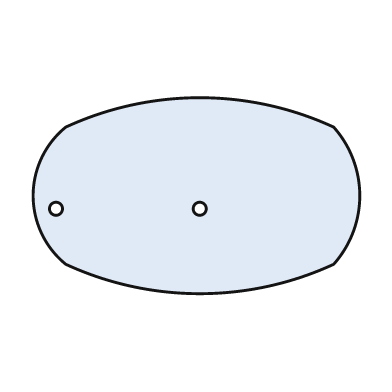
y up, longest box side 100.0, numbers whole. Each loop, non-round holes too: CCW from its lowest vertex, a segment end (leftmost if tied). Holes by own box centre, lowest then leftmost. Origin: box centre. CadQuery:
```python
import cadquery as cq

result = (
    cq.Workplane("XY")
    .moveTo(-40.0, -21.0)
    .threePointArc((1.0, -30.0), (42.0, -21.0))
    .threePointArc((50.0, 0.0), (42.0, 21.0))
    .threePointArc((1.0, 30.0), (-40.0, 21.0))
    .threePointArc((-50.0, 0.0), (-40.0, -21.0))
    .close()
    .moveTo(-43.0, -4.0)
    .circle(2.0)
    .moveTo(1.0, -4.0)
    .circle(2.0)
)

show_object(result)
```